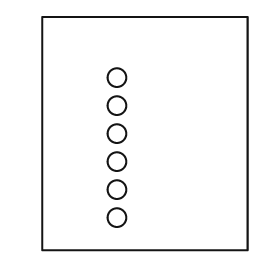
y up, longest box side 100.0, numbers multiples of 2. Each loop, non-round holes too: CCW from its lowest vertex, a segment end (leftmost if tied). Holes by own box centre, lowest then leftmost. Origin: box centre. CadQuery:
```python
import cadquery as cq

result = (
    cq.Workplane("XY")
    .moveTo(-44.0, -50.0)
    .lineTo(44.0, -50.0)
    .lineTo(44.0, 50.0)
    .lineTo(-44.0, 50.0)
    .close()
    .moveTo(-12.0, -36.0)
    .circle(4.0)
    .moveTo(-12.0, -24.0)
    .circle(4.0)
    .moveTo(-12.0, -12.0)
    .circle(4.0)
    .moveTo(-12.0, 0.0)
    .circle(4.0)
    .moveTo(-12.0, 12.0)
    .circle(4.0)
    .moveTo(-12.0, 24.0)
    .circle(4.0)
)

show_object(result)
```